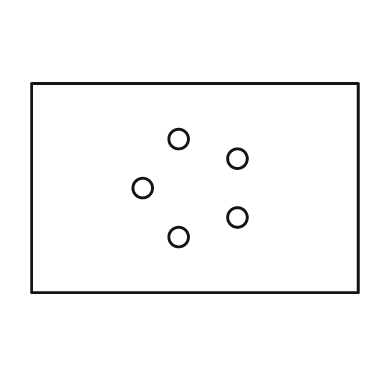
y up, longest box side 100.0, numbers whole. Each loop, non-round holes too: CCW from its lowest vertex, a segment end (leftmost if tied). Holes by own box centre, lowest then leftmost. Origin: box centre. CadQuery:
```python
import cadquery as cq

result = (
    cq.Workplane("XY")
    .moveTo(-50.0, -32.0)
    .lineTo(50.0, -32.0)
    .lineTo(50.0, 32.0)
    .lineTo(-50.0, 32.0)
    .close()
    .moveTo(-5.0, -15.0)
    .circle(3.0)
    .moveTo(13.0, -9.0)
    .circle(3.0)
    .moveTo(-16.0, 0.0)
    .circle(3.0)
    .moveTo(13.0, 9.0)
    .circle(3.0)
    .moveTo(-5.0, 15.0)
    .circle(3.0)
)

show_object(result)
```